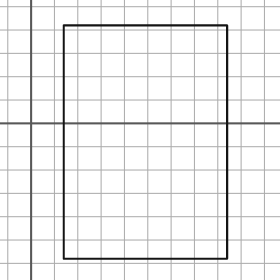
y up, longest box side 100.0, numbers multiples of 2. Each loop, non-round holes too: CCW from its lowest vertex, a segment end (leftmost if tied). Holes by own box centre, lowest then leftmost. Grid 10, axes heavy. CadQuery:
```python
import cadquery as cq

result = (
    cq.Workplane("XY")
    .moveTo(14.0, -58.0)
    .lineTo(84.0, -58.0)
    .lineTo(84.0, 42.0)
    .lineTo(14.0, 42.0)
    .close()
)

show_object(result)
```